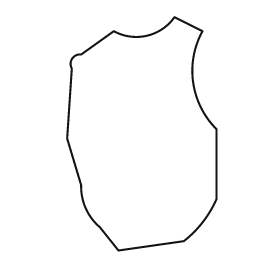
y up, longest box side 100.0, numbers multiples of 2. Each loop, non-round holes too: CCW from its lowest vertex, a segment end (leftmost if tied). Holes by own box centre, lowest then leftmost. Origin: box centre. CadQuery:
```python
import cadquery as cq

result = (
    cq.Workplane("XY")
    .moveTo(-10.0, -50.0)
    .lineTo(18.0, -46.0)
    .threePointArc((26.0, -38.0), (32.0, -28.0))
    .lineTo(32.0, 2.0)
    .threePointArc((22.0, 22.0), (26.0, 44.0))
    .lineTo(14.0, 50.0)
    .threePointArc((2.0, 42.0), (-12.0, 44.0))
    .lineTo(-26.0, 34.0)
    .threePointArc((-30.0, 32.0), (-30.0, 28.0))
    .lineTo(-32.0, -2.0)
    .lineTo(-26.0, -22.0)
    .threePointArc((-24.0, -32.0), (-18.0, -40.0))
    .close()
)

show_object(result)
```